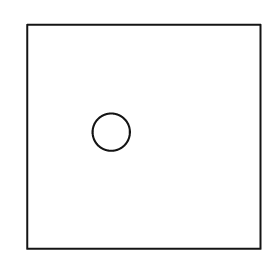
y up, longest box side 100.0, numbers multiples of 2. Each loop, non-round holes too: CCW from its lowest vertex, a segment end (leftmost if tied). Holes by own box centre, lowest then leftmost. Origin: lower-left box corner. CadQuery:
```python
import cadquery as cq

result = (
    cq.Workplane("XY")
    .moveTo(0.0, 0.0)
    .lineTo(100.0, 0.0)
    .lineTo(100.0, 96.0)
    .lineTo(0.0, 96.0)
    .close()
    .moveTo(36.0, 50.0)
    .circle(8.0)
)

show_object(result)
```